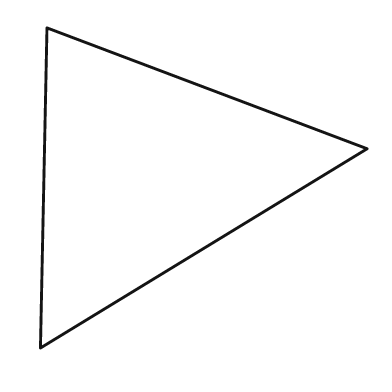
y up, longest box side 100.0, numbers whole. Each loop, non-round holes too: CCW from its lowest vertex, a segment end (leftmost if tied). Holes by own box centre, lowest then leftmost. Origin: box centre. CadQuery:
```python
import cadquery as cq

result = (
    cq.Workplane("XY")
    .moveTo(-50.0, -49.0)
    .lineTo(50.0, 12.0)
    .lineTo(-48.0, 49.0)
    .close()
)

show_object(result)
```